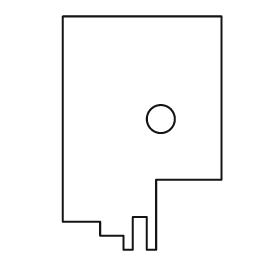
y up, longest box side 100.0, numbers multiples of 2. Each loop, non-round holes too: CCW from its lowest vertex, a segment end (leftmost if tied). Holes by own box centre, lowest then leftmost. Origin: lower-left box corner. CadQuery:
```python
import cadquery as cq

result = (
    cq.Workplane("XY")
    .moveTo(26.0, 0.0)
    .lineTo(30.0, 0.0)
    .lineTo(30.0, 14.0)
    .lineTo(36.0, 14.0)
    .lineTo(36.0, 0.0)
    .lineTo(40.0, 0.0)
    .lineTo(40.0, 30.0)
    .lineTo(68.0, 30.0)
    .lineTo(68.0, 100.0)
    .lineTo(0.0, 100.0)
    .lineTo(0.0, 12.0)
    .lineTo(16.0, 12.0)
    .lineTo(16.0, 6.0)
    .lineTo(26.0, 6.0)
    .close()
    .moveTo(42.0, 56.0)
    .circle(6.0)
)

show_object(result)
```